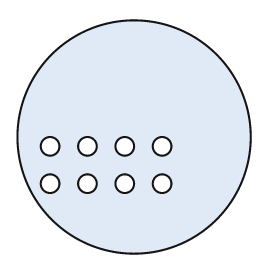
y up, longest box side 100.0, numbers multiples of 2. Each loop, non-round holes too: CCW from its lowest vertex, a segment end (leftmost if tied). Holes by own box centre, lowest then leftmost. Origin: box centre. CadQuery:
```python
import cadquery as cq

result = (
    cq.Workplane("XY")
    .moveTo(0.0, 0.0)
    .circle(50.0)
    .moveTo(-36.0, -20.0)
    .circle(4.0)
    .moveTo(-20.0, -20.0)
    .circle(4.0)
    .moveTo(-4.0, -20.0)
    .circle(4.0)
    .moveTo(12.0, -20.0)
    .circle(4.0)
    .moveTo(-36.0, -4.0)
    .circle(4.0)
    .moveTo(-20.0, -4.0)
    .circle(4.0)
    .moveTo(-4.0, -4.0)
    .circle(4.0)
    .moveTo(12.0, -4.0)
    .circle(4.0)
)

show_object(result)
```